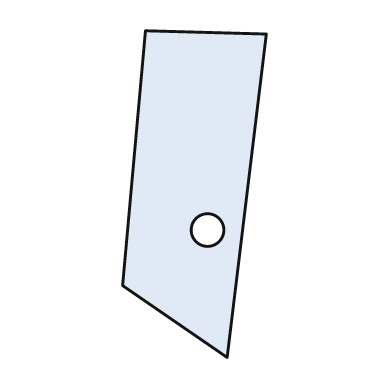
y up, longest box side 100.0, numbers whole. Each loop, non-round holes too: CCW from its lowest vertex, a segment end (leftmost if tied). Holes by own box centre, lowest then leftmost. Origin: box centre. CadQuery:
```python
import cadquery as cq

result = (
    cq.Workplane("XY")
    .moveTo(10.0, -50.0)
    .lineTo(22.0, 49.0)
    .lineTo(-15.0, 50.0)
    .lineTo(-22.0, -28.0)
    .close()
    .moveTo(4.0, -11.0)
    .circle(5.0)
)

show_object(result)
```